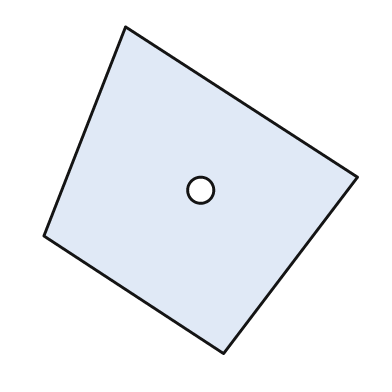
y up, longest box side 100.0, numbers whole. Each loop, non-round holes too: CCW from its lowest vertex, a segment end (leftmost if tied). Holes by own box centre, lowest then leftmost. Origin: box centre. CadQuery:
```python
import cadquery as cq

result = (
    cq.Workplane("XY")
    .moveTo(7.0, -50.0)
    .lineTo(48.0, 4.0)
    .lineTo(-23.0, 50.0)
    .lineTo(-48.0, -14.0)
    .close()
    .moveTo(0.0, 0.0)
    .circle(4.0)
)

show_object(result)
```